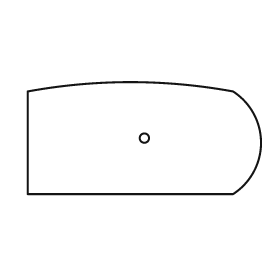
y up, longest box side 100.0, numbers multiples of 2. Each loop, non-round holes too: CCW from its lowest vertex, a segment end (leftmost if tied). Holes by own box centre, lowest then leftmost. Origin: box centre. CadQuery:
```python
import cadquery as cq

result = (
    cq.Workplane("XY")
    .moveTo(-50.0, -24.0)
    .lineTo(38.0, -24.0)
    .threePointArc((50.0, -2.0), (38.0, 20.0))
    .threePointArc((-6.0, 24.0), (-50.0, 20.0))
    .close()
    .moveTo(0.0, 0.0)
    .circle(2.0)
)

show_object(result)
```